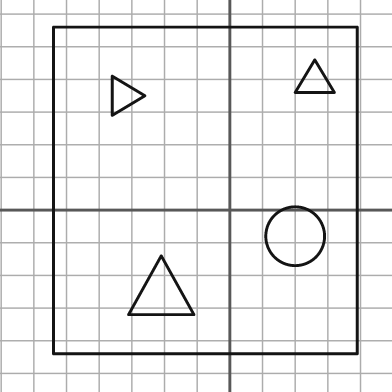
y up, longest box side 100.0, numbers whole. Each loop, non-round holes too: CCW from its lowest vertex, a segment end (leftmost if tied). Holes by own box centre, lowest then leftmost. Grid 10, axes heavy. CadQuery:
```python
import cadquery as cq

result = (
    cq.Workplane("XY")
    .moveTo(-54.0, -44.0)
    .lineTo(39.0, -44.0)
    .lineTo(39.0, 56.0)
    .lineTo(-54.0, 56.0)
    .close()
    .moveTo(-31.0, -32.0)
    .lineTo(-11.0, -32.0)
    .lineTo(-21.0, -14.0)
    .close()
    .moveTo(20.0, -8.0)
    .circle(9.0)
    .moveTo(-36.0, 29.0)
    .lineTo(-26.0, 35.0)
    .lineTo(-36.0, 41.0)
    .close()
    .moveTo(20.0, 36.0)
    .lineTo(32.0, 36.0)
    .lineTo(26.0, 46.0)
    .close()
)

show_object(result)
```